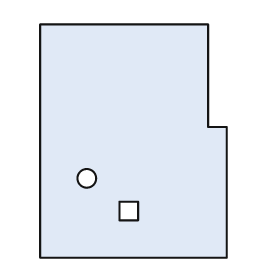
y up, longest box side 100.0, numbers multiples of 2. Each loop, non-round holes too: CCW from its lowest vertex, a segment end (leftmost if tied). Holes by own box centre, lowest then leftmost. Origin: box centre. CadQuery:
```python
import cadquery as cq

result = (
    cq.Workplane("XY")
    .moveTo(-40.0, -50.0)
    .lineTo(40.0, -50.0)
    .lineTo(40.0, 6.0)
    .lineTo(32.0, 6.0)
    .lineTo(32.0, 50.0)
    .lineTo(-40.0, 50.0)
    .close()
    .moveTo(-6.0, -34.0)
    .lineTo(2.0, -34.0)
    .lineTo(2.0, -26.0)
    .lineTo(-6.0, -26.0)
    .close()
    .moveTo(-20.0, -16.0)
    .circle(4.0)
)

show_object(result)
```